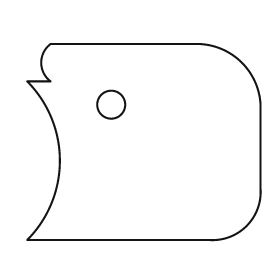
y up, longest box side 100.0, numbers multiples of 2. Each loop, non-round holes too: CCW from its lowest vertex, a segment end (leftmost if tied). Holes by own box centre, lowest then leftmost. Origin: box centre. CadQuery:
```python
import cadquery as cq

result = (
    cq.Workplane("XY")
    .moveTo(-50.0, -42.0)
    .lineTo(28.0, -42.0)
    .threePointArc((44.0, -36.0), (50.0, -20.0))
    .lineTo(50.0, 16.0)
    .threePointArc((42.0, 34.0), (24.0, 42.0))
    .lineTo(-40.0, 42.0)
    .threePointArc((-44.0, 34.0), (-40.0, 26.0))
    .lineTo(-50.0, 26.0)
    .threePointArc((-36.0, -8.0), (-50.0, -42.0))
    .close()
    .moveTo(-14.0, 16.0)
    .circle(6.0)
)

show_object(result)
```